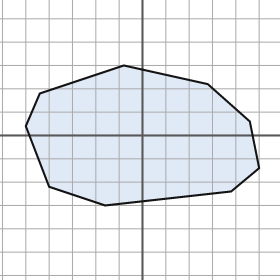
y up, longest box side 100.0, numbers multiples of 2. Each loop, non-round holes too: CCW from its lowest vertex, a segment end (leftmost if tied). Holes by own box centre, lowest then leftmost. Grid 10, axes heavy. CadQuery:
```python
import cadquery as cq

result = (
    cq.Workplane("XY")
    .moveTo(-16.0, -30.0)
    .lineTo(38.0, -24.0)
    .lineTo(50.0, -14.0)
    .lineTo(46.0, 6.0)
    .lineTo(28.0, 22.0)
    .lineTo(-8.0, 30.0)
    .lineTo(-44.0, 18.0)
    .lineTo(-50.0, 4.0)
    .lineTo(-40.0, -22.0)
    .close()
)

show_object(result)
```